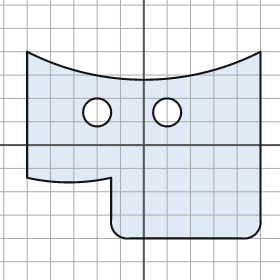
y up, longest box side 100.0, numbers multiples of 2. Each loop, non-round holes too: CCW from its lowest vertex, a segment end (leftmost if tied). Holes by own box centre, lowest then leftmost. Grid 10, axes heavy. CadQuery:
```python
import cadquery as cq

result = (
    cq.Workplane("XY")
    .moveTo(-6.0, -40.0)
    .lineTo(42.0, -40.0)
    .threePointArc((48.0, -38.0), (50.0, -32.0))
    .lineTo(50.0, 40.0)
    .threePointArc((0.0, 28.0), (-50.0, 40.0))
    .lineTo(-50.0, -14.0)
    .threePointArc((-32.0, -16.0), (-14.0, -14.0))
    .lineTo(-14.0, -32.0)
    .threePointArc((-12.0, -38.0), (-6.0, -40.0))
    .close()
    .moveTo(-20.0, 14.0)
    .circle(6.0)
    .moveTo(10.0, 14.0)
    .circle(6.0)
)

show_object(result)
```